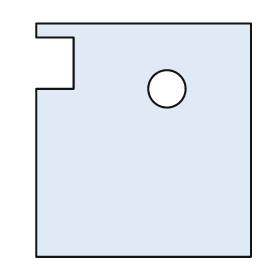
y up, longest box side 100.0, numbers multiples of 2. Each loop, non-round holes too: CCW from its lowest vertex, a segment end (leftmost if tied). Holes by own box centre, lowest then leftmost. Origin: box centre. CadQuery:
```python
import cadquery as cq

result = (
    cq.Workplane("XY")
    .moveTo(-46.0, -50.0)
    .lineTo(46.0, -50.0)
    .lineTo(46.0, 50.0)
    .lineTo(-46.0, 50.0)
    .lineTo(-46.0, 44.0)
    .lineTo(-30.0, 44.0)
    .lineTo(-30.0, 22.0)
    .lineTo(-46.0, 22.0)
    .close()
    .moveTo(10.0, 22.0)
    .circle(8.0)
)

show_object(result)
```